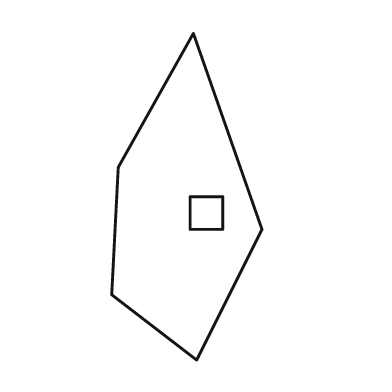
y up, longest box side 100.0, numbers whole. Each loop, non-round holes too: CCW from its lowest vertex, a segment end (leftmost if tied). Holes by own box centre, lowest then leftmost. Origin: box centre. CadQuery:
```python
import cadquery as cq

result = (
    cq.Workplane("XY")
    .moveTo(3.0, -50.0)
    .lineTo(23.0, -10.0)
    .lineTo(2.0, 50.0)
    .lineTo(-21.0, 9.0)
    .lineTo(-23.0, -30.0)
    .close()
    .moveTo(1.0, -10.0)
    .lineTo(11.0, -10.0)
    .lineTo(11.0, 0.0)
    .lineTo(1.0, 0.0)
    .close()
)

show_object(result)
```